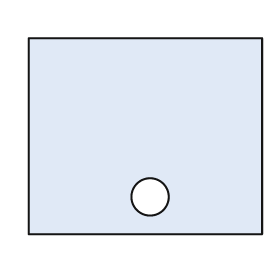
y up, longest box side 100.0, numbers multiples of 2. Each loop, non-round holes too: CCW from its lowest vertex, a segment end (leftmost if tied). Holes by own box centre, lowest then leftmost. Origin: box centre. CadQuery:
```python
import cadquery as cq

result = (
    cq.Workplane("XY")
    .moveTo(-50.0, -42.0)
    .lineTo(50.0, -42.0)
    .lineTo(50.0, 42.0)
    .lineTo(-50.0, 42.0)
    .close()
    .moveTo(2.0, -26.0)
    .circle(8.0)
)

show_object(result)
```